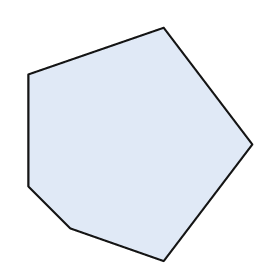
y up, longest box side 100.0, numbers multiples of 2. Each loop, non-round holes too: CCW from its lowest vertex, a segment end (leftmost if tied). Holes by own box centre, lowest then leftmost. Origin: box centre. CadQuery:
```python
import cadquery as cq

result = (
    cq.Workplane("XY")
    .moveTo(10.0, -50.0)
    .lineTo(48.0, 0.0)
    .lineTo(10.0, 50.0)
    .lineTo(-48.0, 30.0)
    .lineTo(-48.0, -18.0)
    .lineTo(-30.0, -36.0)
    .close()
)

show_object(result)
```